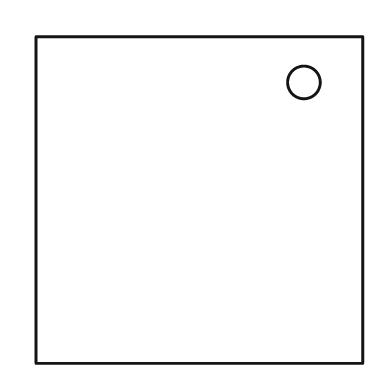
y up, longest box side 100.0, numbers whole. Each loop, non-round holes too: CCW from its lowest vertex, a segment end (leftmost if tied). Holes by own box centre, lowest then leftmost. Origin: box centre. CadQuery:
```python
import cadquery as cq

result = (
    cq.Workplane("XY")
    .moveTo(-50.0, -50.0)
    .lineTo(50.0, -50.0)
    .lineTo(50.0, 50.0)
    .lineTo(-50.0, 50.0)
    .close()
    .moveTo(32.0, 36.0)
    .circle(5.0)
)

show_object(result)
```